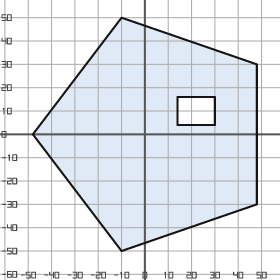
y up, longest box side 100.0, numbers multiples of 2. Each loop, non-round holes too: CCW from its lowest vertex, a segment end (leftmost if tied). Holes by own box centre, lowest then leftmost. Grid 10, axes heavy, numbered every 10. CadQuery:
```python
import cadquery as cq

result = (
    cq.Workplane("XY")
    .moveTo(-10.0, -50.0)
    .lineTo(48.0, -30.0)
    .lineTo(48.0, 30.0)
    .lineTo(-10.0, 50.0)
    .lineTo(-48.0, 0.0)
    .close()
    .moveTo(14.0, 4.0)
    .lineTo(30.0, 4.0)
    .lineTo(30.0, 16.0)
    .lineTo(14.0, 16.0)
    .close()
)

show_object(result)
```